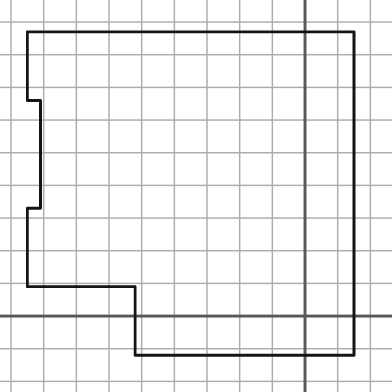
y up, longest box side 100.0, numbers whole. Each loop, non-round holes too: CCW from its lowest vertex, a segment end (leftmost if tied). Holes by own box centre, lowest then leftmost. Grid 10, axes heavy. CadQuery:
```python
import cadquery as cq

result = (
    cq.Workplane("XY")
    .moveTo(-52.0, -12.0)
    .lineTo(15.0, -12.0)
    .lineTo(15.0, 87.0)
    .lineTo(-85.0, 87.0)
    .lineTo(-85.0, 66.0)
    .lineTo(-81.0, 66.0)
    .lineTo(-81.0, 33.0)
    .lineTo(-85.0, 33.0)
    .lineTo(-85.0, 9.0)
    .lineTo(-52.0, 9.0)
    .close()
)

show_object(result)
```